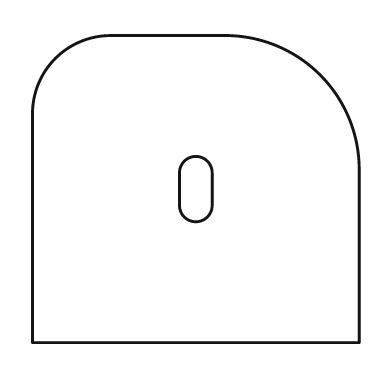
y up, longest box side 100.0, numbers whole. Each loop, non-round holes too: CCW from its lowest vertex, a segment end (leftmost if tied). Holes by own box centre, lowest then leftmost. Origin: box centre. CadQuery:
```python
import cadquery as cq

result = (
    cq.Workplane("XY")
    .moveTo(-50.0, -47.0)
    .lineTo(50.0, -47.0)
    .lineTo(50.0, 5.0)
    .threePointArc((38.0, 35.0), (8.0, 47.0))
    .lineTo(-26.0, 47.0)
    .threePointArc((-43.0, 40.0), (-50.0, 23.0))
    .close()
    .moveTo(-5.0, -5.0)
    .threePointArc((0.0, -10.0), (5.0, -5.0))
    .lineTo(5.0, 5.0)
    .threePointArc((0.0, 10.0), (-5.0, 5.0))
    .close()
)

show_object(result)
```